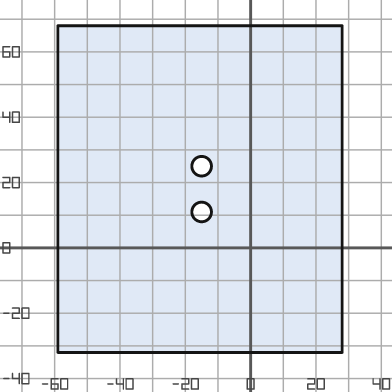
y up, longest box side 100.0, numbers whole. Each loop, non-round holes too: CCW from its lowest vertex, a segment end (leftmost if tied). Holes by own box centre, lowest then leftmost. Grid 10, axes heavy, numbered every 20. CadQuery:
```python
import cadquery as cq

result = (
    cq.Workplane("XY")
    .moveTo(-59.0, -32.0)
    .lineTo(28.0, -32.0)
    .lineTo(28.0, 68.0)
    .lineTo(-59.0, 68.0)
    .close()
    .moveTo(-15.0, 11.0)
    .circle(3.0)
    .moveTo(-15.0, 25.0)
    .circle(3.0)
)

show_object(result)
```